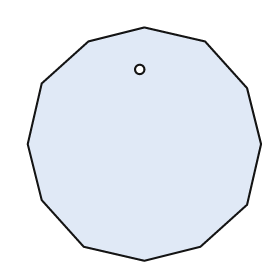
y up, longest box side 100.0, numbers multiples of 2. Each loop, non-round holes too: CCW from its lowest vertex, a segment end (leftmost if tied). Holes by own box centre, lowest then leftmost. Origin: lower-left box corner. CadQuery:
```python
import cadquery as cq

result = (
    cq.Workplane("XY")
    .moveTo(50.0, 0.0)
    .lineTo(74.0, 6.0)
    .lineTo(94.0, 24.0)
    .lineTo(100.0, 50.0)
    .lineTo(94.0, 74.0)
    .lineTo(76.0, 94.0)
    .lineTo(50.0, 100.0)
    .lineTo(26.0, 94.0)
    .lineTo(6.0, 76.0)
    .lineTo(0.0, 50.0)
    .lineTo(6.0, 26.0)
    .lineTo(24.0, 6.0)
    .close()
    .moveTo(48.0, 82.0)
    .circle(2.0)
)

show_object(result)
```